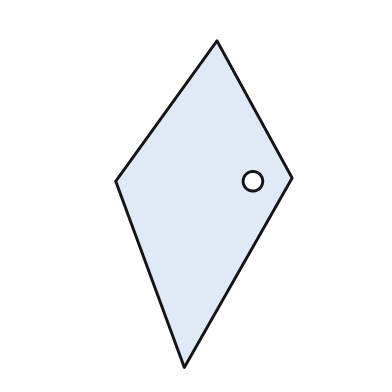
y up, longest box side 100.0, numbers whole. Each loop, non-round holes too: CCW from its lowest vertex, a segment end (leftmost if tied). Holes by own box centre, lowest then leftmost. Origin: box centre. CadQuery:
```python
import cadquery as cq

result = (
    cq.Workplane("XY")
    .moveTo(-6.0, -50.0)
    .lineTo(27.0, 8.0)
    .lineTo(4.0, 50.0)
    .lineTo(-27.0, 7.0)
    .close()
    .moveTo(15.0, 7.0)
    .circle(3.0)
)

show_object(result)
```